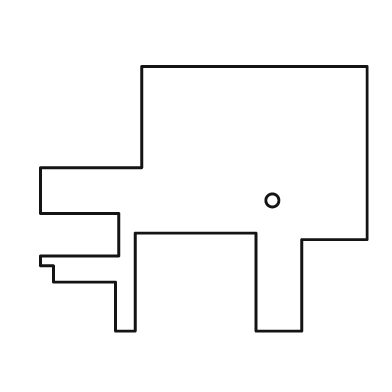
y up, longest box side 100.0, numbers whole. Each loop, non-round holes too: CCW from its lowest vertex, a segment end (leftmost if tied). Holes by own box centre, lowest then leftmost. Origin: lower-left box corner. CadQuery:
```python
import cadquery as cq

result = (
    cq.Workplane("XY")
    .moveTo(23.0, 0.0)
    .lineTo(29.0, 0.0)
    .lineTo(29.0, 30.0)
    .lineTo(66.0, 30.0)
    .lineTo(66.0, 0.0)
    .lineTo(80.0, 0.0)
    .lineTo(80.0, 28.0)
    .lineTo(100.0, 28.0)
    .lineTo(100.0, 81.0)
    .lineTo(31.0, 81.0)
    .lineTo(31.0, 50.0)
    .lineTo(0.0, 50.0)
    .lineTo(0.0, 36.0)
    .lineTo(24.0, 36.0)
    .lineTo(24.0, 23.0)
    .lineTo(0.0, 23.0)
    .lineTo(0.0, 20.0)
    .lineTo(4.0, 20.0)
    .lineTo(4.0, 15.0)
    .lineTo(23.0, 15.0)
    .close()
    .moveTo(71.0, 40.0)
    .circle(2.0)
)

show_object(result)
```